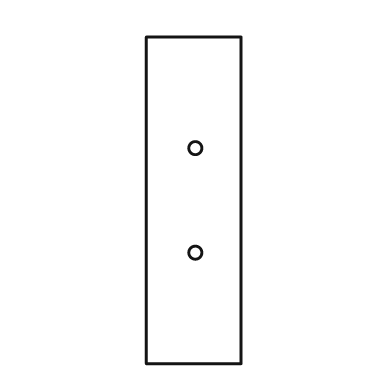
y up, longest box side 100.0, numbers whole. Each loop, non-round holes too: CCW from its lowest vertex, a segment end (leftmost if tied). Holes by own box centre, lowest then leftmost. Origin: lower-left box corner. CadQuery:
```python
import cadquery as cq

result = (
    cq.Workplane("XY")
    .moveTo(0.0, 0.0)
    .lineTo(29.0, 0.0)
    .lineTo(29.0, 100.0)
    .lineTo(0.0, 100.0)
    .close()
    .moveTo(15.0, 34.0)
    .circle(2.0)
    .moveTo(15.0, 66.0)
    .circle(2.0)
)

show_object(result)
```